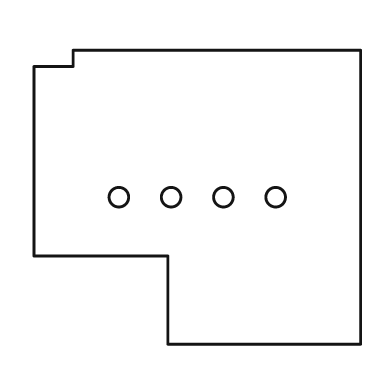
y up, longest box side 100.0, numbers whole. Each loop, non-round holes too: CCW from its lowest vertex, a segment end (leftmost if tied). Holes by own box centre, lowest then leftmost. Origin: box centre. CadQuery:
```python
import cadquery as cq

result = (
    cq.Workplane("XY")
    .moveTo(-9.0, -45.0)
    .lineTo(50.0, -45.0)
    .lineTo(50.0, 45.0)
    .lineTo(-38.0, 45.0)
    .lineTo(-38.0, 40.0)
    .lineTo(-50.0, 40.0)
    .lineTo(-50.0, -18.0)
    .lineTo(-9.0, -18.0)
    .close()
    .moveTo(-24.0, 0.0)
    .circle(3.0)
    .moveTo(-8.0, 0.0)
    .circle(3.0)
    .moveTo(8.0, 0.0)
    .circle(3.0)
    .moveTo(24.0, 0.0)
    .circle(3.0)
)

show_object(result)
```